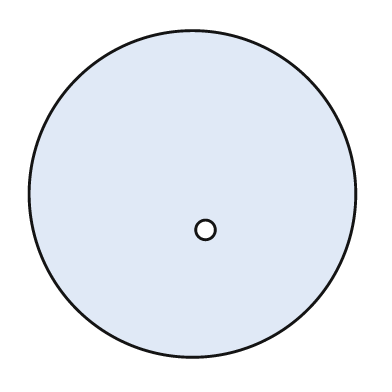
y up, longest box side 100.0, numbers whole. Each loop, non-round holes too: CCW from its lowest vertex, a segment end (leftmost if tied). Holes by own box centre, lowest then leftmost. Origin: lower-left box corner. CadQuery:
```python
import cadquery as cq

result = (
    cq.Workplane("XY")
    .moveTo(50.0, 50.0)
    .circle(50.0)
    .moveTo(54.0, 39.0)
    .circle(3.0)
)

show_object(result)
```